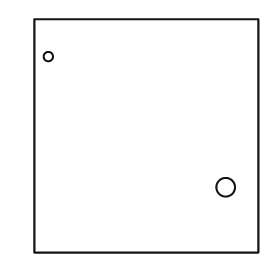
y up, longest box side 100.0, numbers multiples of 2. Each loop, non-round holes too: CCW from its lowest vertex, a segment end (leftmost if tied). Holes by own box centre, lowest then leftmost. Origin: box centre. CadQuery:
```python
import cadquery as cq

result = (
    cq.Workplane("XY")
    .moveTo(-48.0, -50.0)
    .lineTo(48.0, -50.0)
    .lineTo(48.0, 50.0)
    .lineTo(-48.0, 50.0)
    .close()
    .moveTo(34.0, -22.0)
    .circle(4.0)
    .moveTo(-42.0, 34.0)
    .circle(2.0)
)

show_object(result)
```